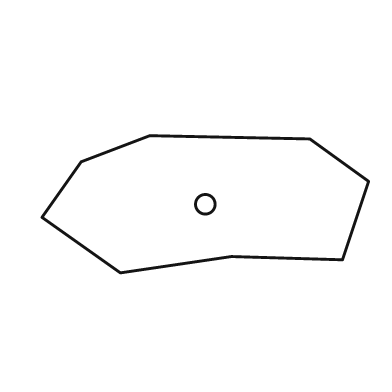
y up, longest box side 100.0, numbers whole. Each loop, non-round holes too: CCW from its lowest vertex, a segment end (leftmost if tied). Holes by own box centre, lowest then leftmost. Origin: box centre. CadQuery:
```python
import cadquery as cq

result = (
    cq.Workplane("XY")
    .moveTo(-26.0, -21.0)
    .lineTo(8.0, -16.0)
    .lineTo(42.0, -17.0)
    .lineTo(50.0, 7.0)
    .lineTo(32.0, 20.0)
    .lineTo(-17.0, 21.0)
    .lineTo(-38.0, 13.0)
    .lineTo(-50.0, -4.0)
    .close()
    .moveTo(0.0, 0.0)
    .circle(3.0)
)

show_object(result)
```